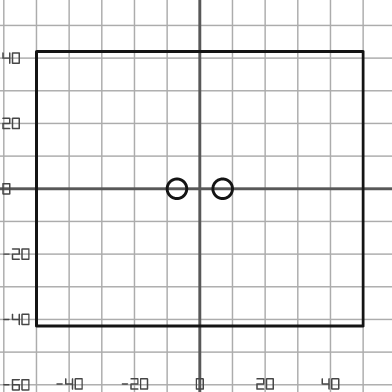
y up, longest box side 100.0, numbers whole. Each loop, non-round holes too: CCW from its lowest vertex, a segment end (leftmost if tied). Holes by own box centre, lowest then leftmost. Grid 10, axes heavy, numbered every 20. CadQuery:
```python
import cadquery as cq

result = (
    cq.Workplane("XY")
    .moveTo(-50.0, -42.0)
    .lineTo(50.0, -42.0)
    .lineTo(50.0, 42.0)
    .lineTo(-50.0, 42.0)
    .close()
    .moveTo(-7.0, 0.0)
    .circle(3.0)
    .moveTo(7.0, 0.0)
    .circle(3.0)
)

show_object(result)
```